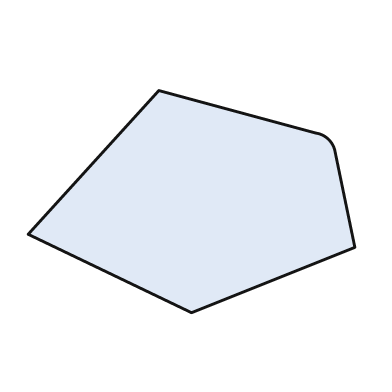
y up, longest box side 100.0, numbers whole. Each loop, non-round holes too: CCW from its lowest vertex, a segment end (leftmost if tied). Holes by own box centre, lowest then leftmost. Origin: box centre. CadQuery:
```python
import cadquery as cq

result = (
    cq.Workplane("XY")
    .moveTo(0.0, -34.0)
    .lineTo(50.0, -14.0)
    .lineTo(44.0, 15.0)
    .threePointArc((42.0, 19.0), (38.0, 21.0))
    .lineTo(-10.0, 34.0)
    .lineTo(-50.0, -10.0)
    .close()
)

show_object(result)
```